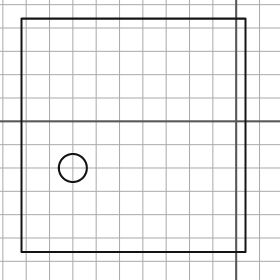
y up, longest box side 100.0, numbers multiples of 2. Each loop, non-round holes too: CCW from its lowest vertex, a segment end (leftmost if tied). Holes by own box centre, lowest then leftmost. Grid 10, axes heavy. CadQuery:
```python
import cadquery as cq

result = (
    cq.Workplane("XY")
    .moveTo(-92.0, -56.0)
    .lineTo(4.0, -56.0)
    .lineTo(4.0, 44.0)
    .lineTo(-92.0, 44.0)
    .close()
    .moveTo(-70.0, -20.0)
    .circle(6.0)
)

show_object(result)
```